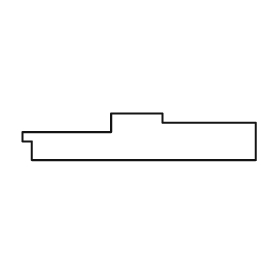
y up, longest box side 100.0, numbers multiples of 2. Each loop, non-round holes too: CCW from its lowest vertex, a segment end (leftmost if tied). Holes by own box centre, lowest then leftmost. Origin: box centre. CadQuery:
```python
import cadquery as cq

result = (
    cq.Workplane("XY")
    .moveTo(-46.0, -10.0)
    .lineTo(50.0, -10.0)
    .lineTo(50.0, 6.0)
    .lineTo(10.0, 6.0)
    .lineTo(10.0, 10.0)
    .lineTo(-12.0, 10.0)
    .lineTo(-12.0, 2.0)
    .lineTo(-50.0, 2.0)
    .lineTo(-50.0, -2.0)
    .lineTo(-46.0, -2.0)
    .close()
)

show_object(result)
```